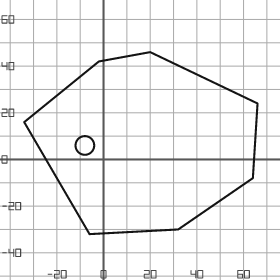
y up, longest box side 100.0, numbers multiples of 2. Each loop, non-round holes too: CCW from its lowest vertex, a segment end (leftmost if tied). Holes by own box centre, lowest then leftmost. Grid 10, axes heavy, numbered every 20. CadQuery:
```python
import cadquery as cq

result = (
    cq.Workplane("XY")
    .moveTo(-6.0, -32.0)
    .lineTo(32.0, -30.0)
    .lineTo(64.0, -8.0)
    .lineTo(66.0, 24.0)
    .lineTo(20.0, 46.0)
    .lineTo(-2.0, 42.0)
    .lineTo(-34.0, 16.0)
    .close()
    .moveTo(-8.0, 6.0)
    .circle(4.0)
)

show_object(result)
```